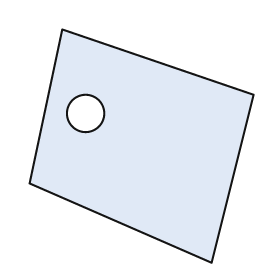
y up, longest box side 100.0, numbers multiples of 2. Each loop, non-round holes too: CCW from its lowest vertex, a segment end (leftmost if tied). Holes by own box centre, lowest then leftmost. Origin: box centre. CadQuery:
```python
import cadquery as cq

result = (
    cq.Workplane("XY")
    .moveTo(30.0, -50.0)
    .lineTo(48.0, 22.0)
    .lineTo(-34.0, 50.0)
    .lineTo(-48.0, -16.0)
    .close()
    .moveTo(-24.0, 14.0)
    .circle(8.0)
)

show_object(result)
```